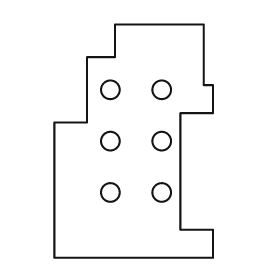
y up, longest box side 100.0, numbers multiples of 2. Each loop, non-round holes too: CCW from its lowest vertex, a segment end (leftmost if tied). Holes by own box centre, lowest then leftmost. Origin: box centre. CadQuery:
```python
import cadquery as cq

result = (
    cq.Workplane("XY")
    .moveTo(-34.0, -50.0)
    .lineTo(34.0, -50.0)
    .lineTo(34.0, -38.0)
    .lineTo(20.0, -38.0)
    .lineTo(20.0, 12.0)
    .lineTo(34.0, 12.0)
    .lineTo(34.0, 24.0)
    .lineTo(30.0, 24.0)
    .lineTo(30.0, 50.0)
    .lineTo(-8.0, 50.0)
    .lineTo(-8.0, 36.0)
    .lineTo(-20.0, 36.0)
    .lineTo(-20.0, 8.0)
    .lineTo(-34.0, 8.0)
    .close()
    .moveTo(-10.0, -22.0)
    .circle(4.0)
    .moveTo(12.0, -22.0)
    .circle(4.0)
    .moveTo(-10.0, 0.0)
    .circle(4.0)
    .moveTo(12.0, 0.0)
    .circle(4.0)
    .moveTo(-10.0, 22.0)
    .circle(4.0)
    .moveTo(12.0, 22.0)
    .circle(4.0)
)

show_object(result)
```